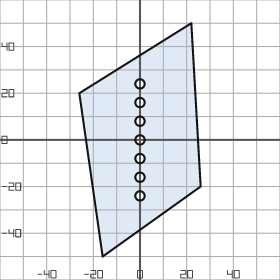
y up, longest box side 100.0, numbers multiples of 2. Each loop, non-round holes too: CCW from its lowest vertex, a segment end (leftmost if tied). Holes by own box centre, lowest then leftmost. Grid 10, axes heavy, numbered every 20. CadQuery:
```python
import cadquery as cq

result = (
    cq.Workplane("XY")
    .moveTo(-16.0, -50.0)
    .lineTo(26.0, -20.0)
    .lineTo(22.0, 50.0)
    .lineTo(-26.0, 20.0)
    .close()
    .moveTo(0.0, -24.0)
    .circle(2.0)
    .moveTo(0.0, -16.0)
    .circle(2.0)
    .moveTo(0.0, -8.0)
    .circle(2.0)
    .moveTo(0.0, 0.0)
    .circle(2.0)
    .moveTo(0.0, 8.0)
    .circle(2.0)
    .moveTo(0.0, 16.0)
    .circle(2.0)
    .moveTo(0.0, 24.0)
    .circle(2.0)
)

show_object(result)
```